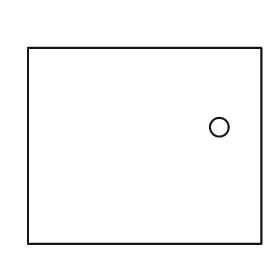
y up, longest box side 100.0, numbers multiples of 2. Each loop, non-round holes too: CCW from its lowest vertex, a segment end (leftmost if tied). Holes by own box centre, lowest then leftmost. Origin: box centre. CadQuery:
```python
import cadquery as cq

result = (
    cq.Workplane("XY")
    .moveTo(-50.0, -42.0)
    .lineTo(50.0, -42.0)
    .lineTo(50.0, 42.0)
    .lineTo(-50.0, 42.0)
    .close()
    .moveTo(32.0, 8.0)
    .circle(4.0)
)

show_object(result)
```